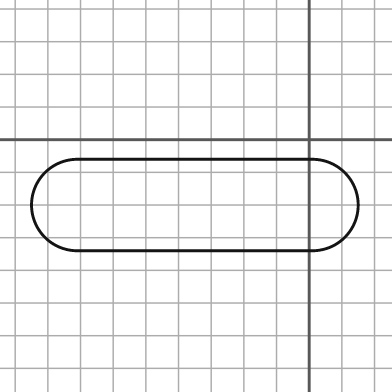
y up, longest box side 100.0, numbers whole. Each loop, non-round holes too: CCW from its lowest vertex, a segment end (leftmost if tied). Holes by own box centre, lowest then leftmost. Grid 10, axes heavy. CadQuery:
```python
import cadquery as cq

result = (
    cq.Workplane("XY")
    .moveTo(-71.0, -34.0)
    .lineTo(1.0, -34.0)
    .threePointArc((15.0, -20.0), (1.0, -6.0))
    .lineTo(-71.0, -6.0)
    .threePointArc((-85.0, -20.0), (-71.0, -34.0))
    .close()
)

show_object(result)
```